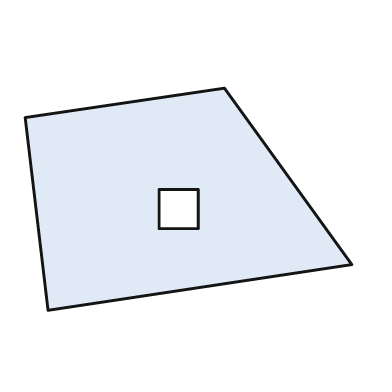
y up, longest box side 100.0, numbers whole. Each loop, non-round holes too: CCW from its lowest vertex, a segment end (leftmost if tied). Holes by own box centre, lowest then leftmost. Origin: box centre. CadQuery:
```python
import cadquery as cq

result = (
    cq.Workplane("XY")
    .moveTo(-43.0, -34.0)
    .lineTo(50.0, -20.0)
    .lineTo(11.0, 34.0)
    .lineTo(-50.0, 25.0)
    .close()
    .moveTo(-9.0, -9.0)
    .lineTo(3.0, -9.0)
    .lineTo(3.0, 3.0)
    .lineTo(-9.0, 3.0)
    .close()
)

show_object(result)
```